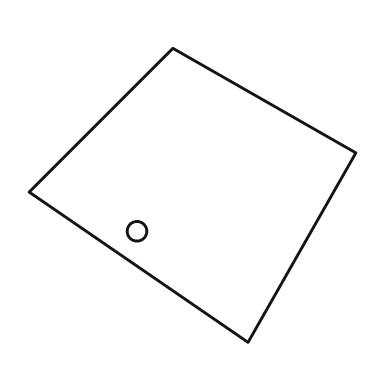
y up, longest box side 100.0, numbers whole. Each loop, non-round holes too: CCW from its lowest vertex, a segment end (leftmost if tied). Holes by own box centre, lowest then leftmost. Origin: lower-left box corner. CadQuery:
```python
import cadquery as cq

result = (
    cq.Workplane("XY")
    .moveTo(67.0, 0.0)
    .lineTo(100.0, 58.0)
    .lineTo(44.0, 90.0)
    .lineTo(0.0, 46.0)
    .close()
    .moveTo(33.0, 34.0)
    .circle(3.0)
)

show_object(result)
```